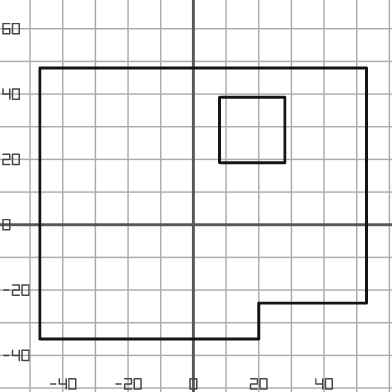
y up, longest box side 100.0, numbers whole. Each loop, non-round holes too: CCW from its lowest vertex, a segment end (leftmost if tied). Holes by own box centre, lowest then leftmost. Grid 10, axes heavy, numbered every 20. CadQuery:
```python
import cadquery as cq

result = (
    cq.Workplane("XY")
    .moveTo(-47.0, -35.0)
    .lineTo(20.0, -35.0)
    .lineTo(20.0, -24.0)
    .lineTo(53.0, -24.0)
    .lineTo(53.0, 48.0)
    .lineTo(-47.0, 48.0)
    .close()
    .moveTo(8.0, 19.0)
    .lineTo(28.0, 19.0)
    .lineTo(28.0, 39.0)
    .lineTo(8.0, 39.0)
    .close()
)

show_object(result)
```